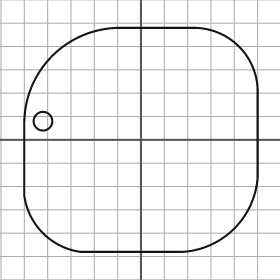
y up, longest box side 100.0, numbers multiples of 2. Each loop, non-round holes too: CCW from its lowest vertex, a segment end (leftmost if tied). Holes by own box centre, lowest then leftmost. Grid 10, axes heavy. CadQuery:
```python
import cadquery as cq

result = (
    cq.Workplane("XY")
    .moveTo(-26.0, -48.0)
    .lineTo(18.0, -48.0)
    .threePointArc((40.0, -38.0), (50.0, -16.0))
    .lineTo(50.0, 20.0)
    .threePointArc((42.0, 40.0), (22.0, 48.0))
    .lineTo(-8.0, 48.0)
    .threePointArc((-38.0, 36.0), (-50.0, 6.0))
    .lineTo(-50.0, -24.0)
    .threePointArc((-42.0, -40.0), (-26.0, -48.0))
    .close()
    .moveTo(-42.0, 8.0)
    .circle(4.0)
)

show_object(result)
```